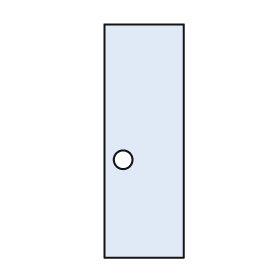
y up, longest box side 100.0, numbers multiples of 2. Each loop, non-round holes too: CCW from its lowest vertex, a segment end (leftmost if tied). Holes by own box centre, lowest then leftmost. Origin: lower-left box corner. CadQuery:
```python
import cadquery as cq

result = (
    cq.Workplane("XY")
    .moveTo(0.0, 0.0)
    .lineTo(34.0, 0.0)
    .lineTo(34.0, 100.0)
    .lineTo(0.0, 100.0)
    .close()
    .moveTo(8.0, 42.0)
    .circle(4.0)
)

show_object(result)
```